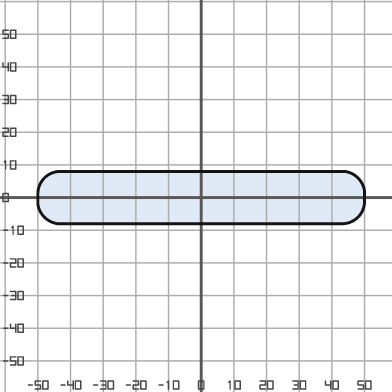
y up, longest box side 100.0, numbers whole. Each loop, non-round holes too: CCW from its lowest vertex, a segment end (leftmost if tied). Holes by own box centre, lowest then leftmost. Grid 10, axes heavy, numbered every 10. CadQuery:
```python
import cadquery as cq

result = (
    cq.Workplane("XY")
    .moveTo(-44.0, -8.0)
    .lineTo(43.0, -8.0)
    .threePointArc((48.0, -6.0), (50.0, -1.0))
    .lineTo(50.0, 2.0)
    .threePointArc((48.0, 6.0), (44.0, 8.0))
    .lineTo(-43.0, 8.0)
    .threePointArc((-48.0, 6.0), (-50.0, 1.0))
    .lineTo(-50.0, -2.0)
    .threePointArc((-48.0, -6.0), (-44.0, -8.0))
    .close()
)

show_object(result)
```